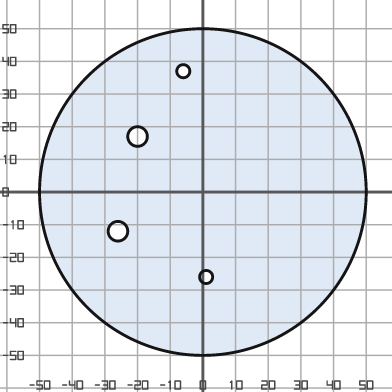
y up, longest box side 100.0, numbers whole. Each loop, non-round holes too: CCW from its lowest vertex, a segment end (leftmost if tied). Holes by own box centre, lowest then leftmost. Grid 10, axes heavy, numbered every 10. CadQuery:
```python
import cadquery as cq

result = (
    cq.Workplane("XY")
    .moveTo(0.0, 0.0)
    .circle(50.0)
    .moveTo(1.0, -26.0)
    .circle(2.0)
    .moveTo(-26.0, -12.0)
    .circle(3.0)
    .moveTo(-20.0, 17.0)
    .circle(3.0)
    .moveTo(-6.0, 37.0)
    .circle(2.0)
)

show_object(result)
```